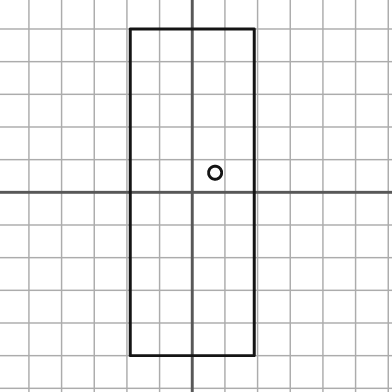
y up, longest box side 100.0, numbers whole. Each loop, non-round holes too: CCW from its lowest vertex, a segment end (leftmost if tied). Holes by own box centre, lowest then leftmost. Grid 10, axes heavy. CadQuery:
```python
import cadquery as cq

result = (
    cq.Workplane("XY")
    .moveTo(-19.0, -50.0)
    .lineTo(19.0, -50.0)
    .lineTo(19.0, 50.0)
    .lineTo(-19.0, 50.0)
    .close()
    .moveTo(7.0, 6.0)
    .circle(2.0)
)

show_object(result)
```